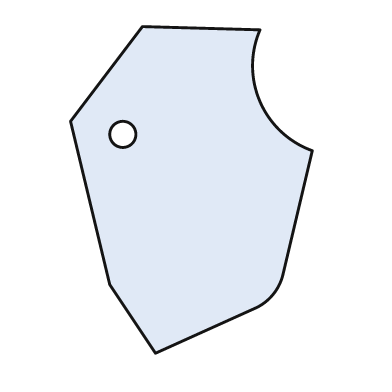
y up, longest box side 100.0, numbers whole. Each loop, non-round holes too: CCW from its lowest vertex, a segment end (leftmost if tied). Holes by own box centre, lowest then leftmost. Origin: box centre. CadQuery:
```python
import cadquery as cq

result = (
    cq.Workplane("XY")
    .moveTo(-11.0, -50.0)
    .lineTo(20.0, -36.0)
    .threePointArc((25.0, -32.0), (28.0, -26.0))
    .lineTo(37.0, 12.0)
    .threePointArc((21.0, 27.0), (21.0, 49.0))
    .lineTo(-15.0, 50.0)
    .lineTo(-37.0, 21.0)
    .lineTo(-25.0, -29.0)
    .close()
    .moveTo(-21.0, 17.0)
    .circle(4.0)
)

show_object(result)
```